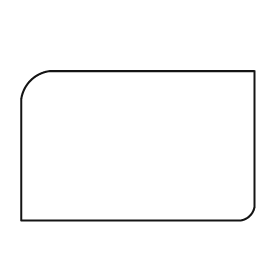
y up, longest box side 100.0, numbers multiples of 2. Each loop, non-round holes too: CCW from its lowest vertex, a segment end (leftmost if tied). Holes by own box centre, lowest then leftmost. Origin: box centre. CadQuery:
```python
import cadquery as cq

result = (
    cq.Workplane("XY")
    .moveTo(-50.0, -32.0)
    .lineTo(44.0, -32.0)
    .threePointArc((48.0, -30.0), (50.0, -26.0))
    .lineTo(50.0, 32.0)
    .lineTo(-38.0, 32.0)
    .threePointArc((-46.0, 28.0), (-50.0, 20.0))
    .close()
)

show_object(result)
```